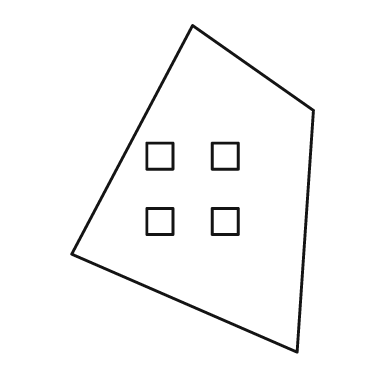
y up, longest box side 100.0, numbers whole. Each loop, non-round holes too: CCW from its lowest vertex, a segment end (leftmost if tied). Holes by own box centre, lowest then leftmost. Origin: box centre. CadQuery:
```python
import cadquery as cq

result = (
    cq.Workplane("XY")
    .moveTo(32.0, -50.0)
    .lineTo(37.0, 24.0)
    .lineTo(0.0, 50.0)
    .lineTo(-37.0, -20.0)
    .close()
    .moveTo(-14.0, -14.0)
    .lineTo(-6.0, -14.0)
    .lineTo(-6.0, -6.0)
    .lineTo(-14.0, -6.0)
    .close()
    .moveTo(6.0, -14.0)
    .lineTo(14.0, -14.0)
    .lineTo(14.0, -6.0)
    .lineTo(6.0, -6.0)
    .close()
    .moveTo(-14.0, 6.0)
    .lineTo(-6.0, 6.0)
    .lineTo(-6.0, 14.0)
    .lineTo(-14.0, 14.0)
    .close()
    .moveTo(6.0, 6.0)
    .lineTo(14.0, 6.0)
    .lineTo(14.0, 14.0)
    .lineTo(6.0, 14.0)
    .close()
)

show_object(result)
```